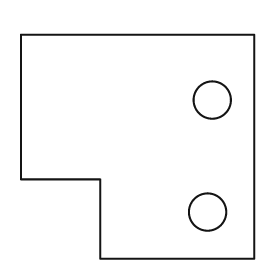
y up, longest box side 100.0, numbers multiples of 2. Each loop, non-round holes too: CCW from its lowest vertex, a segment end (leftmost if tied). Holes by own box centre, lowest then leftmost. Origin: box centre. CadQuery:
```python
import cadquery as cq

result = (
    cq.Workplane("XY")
    .moveTo(-16.0, -48.0)
    .lineTo(50.0, -48.0)
    .lineTo(50.0, 48.0)
    .lineTo(-50.0, 48.0)
    .lineTo(-50.0, -14.0)
    .lineTo(-16.0, -14.0)
    .close()
    .moveTo(30.0, -28.0)
    .circle(8.0)
    .moveTo(32.0, 20.0)
    .circle(8.0)
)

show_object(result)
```